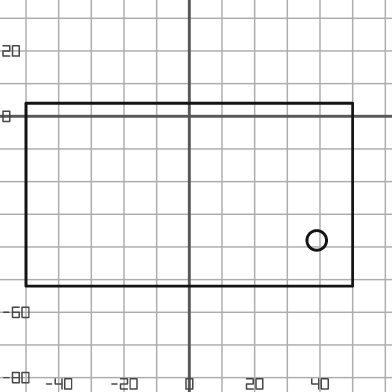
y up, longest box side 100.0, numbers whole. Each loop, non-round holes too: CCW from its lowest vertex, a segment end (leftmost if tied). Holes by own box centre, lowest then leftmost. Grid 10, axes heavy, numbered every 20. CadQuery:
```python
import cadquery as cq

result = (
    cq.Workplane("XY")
    .moveTo(-50.0, -52.0)
    .lineTo(50.0, -52.0)
    .lineTo(50.0, 4.0)
    .lineTo(-50.0, 4.0)
    .close()
    .moveTo(39.0, -38.0)
    .circle(3.0)
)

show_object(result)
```